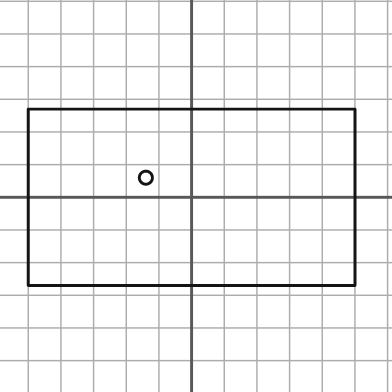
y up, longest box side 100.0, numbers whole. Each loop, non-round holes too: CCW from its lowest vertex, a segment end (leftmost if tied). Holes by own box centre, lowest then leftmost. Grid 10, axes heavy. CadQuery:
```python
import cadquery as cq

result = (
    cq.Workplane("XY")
    .moveTo(-50.0, -27.0)
    .lineTo(50.0, -27.0)
    .lineTo(50.0, 27.0)
    .lineTo(-50.0, 27.0)
    .close()
    .moveTo(-14.0, 6.0)
    .circle(2.0)
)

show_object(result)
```